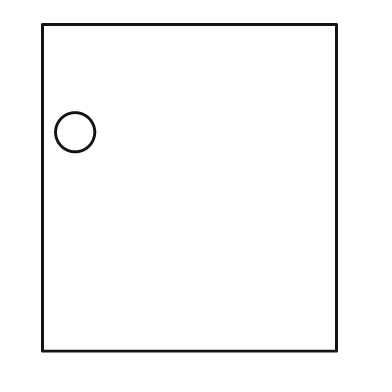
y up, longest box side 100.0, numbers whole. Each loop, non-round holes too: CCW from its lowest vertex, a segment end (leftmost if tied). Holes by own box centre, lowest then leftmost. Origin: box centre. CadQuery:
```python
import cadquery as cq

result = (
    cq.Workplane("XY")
    .moveTo(-45.0, -50.0)
    .lineTo(45.0, -50.0)
    .lineTo(45.0, 50.0)
    .lineTo(-45.0, 50.0)
    .close()
    .moveTo(-35.0, 17.0)
    .circle(6.0)
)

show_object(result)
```